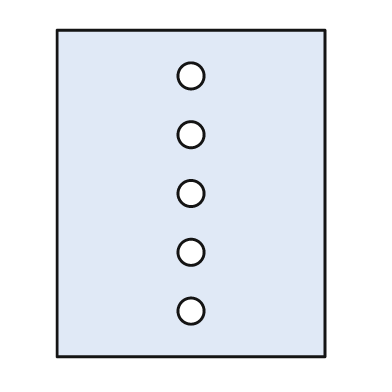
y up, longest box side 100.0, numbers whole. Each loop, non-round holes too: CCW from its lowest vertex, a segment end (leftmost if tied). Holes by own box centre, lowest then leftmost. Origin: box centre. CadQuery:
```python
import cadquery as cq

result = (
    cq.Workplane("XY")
    .moveTo(-41.0, -50.0)
    .lineTo(41.0, -50.0)
    .lineTo(41.0, 50.0)
    .lineTo(-41.0, 50.0)
    .close()
    .moveTo(0.0, -36.0)
    .circle(4.0)
    .moveTo(0.0, -18.0)
    .circle(4.0)
    .moveTo(0.0, 0.0)
    .circle(4.0)
    .moveTo(0.0, 18.0)
    .circle(4.0)
    .moveTo(0.0, 36.0)
    .circle(4.0)
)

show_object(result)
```